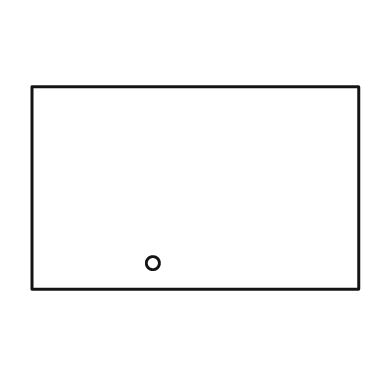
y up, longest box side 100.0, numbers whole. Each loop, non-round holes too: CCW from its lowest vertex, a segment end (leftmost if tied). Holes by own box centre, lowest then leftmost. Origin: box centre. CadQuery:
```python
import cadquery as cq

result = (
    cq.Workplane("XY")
    .moveTo(-50.0, -31.0)
    .lineTo(50.0, -31.0)
    .lineTo(50.0, 31.0)
    .lineTo(-50.0, 31.0)
    .close()
    .moveTo(-13.0, -23.0)
    .circle(2.0)
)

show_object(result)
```